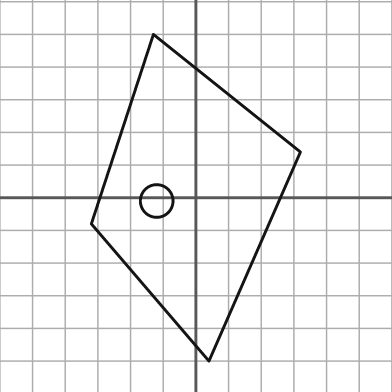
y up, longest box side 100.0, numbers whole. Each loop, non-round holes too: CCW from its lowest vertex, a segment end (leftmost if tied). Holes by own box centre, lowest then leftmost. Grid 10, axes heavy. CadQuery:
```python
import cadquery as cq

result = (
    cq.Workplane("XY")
    .moveTo(4.0, -50.0)
    .lineTo(32.0, 14.0)
    .lineTo(-13.0, 50.0)
    .lineTo(-32.0, -8.0)
    .close()
    .moveTo(-12.0, -1.0)
    .circle(5.0)
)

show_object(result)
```